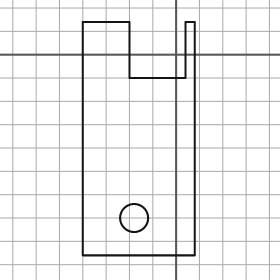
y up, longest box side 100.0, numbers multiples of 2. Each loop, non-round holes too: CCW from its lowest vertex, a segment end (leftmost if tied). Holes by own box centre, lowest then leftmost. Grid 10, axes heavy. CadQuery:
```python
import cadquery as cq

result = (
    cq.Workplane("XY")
    .moveTo(-40.0, -86.0)
    .lineTo(8.0, -86.0)
    .lineTo(8.0, 14.0)
    .lineTo(4.0, 14.0)
    .lineTo(4.0, -10.0)
    .lineTo(-20.0, -10.0)
    .lineTo(-20.0, 14.0)
    .lineTo(-40.0, 14.0)
    .close()
    .moveTo(-18.0, -70.0)
    .circle(6.0)
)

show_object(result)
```